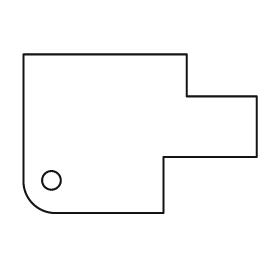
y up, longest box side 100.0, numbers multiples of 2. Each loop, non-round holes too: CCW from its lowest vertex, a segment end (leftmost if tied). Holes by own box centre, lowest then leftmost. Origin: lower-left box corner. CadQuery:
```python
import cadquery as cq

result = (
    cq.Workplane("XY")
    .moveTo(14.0, 0.0)
    .lineTo(60.0, 0.0)
    .lineTo(60.0, 24.0)
    .lineTo(100.0, 24.0)
    .lineTo(100.0, 50.0)
    .lineTo(70.0, 50.0)
    .lineTo(70.0, 68.0)
    .lineTo(0.0, 68.0)
    .lineTo(0.0, 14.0)
    .threePointArc((4.0, 4.0), (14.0, 0.0))
    .close()
    .moveTo(12.0, 14.0)
    .circle(4.0)
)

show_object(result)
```